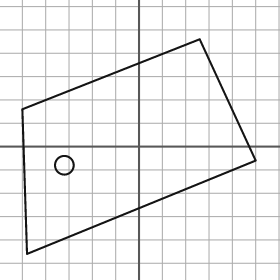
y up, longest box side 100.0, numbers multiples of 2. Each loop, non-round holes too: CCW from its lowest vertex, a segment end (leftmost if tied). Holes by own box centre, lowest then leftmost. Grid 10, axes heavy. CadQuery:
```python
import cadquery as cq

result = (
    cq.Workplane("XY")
    .moveTo(-48.0, -46.0)
    .lineTo(50.0, -6.0)
    .lineTo(26.0, 46.0)
    .lineTo(-50.0, 16.0)
    .close()
    .moveTo(-32.0, -8.0)
    .circle(4.0)
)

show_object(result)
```